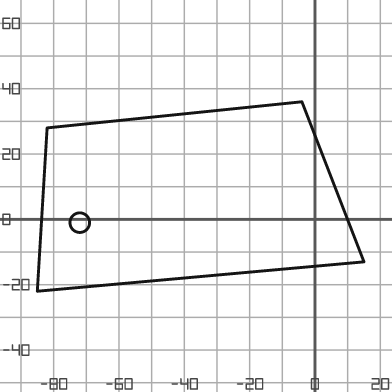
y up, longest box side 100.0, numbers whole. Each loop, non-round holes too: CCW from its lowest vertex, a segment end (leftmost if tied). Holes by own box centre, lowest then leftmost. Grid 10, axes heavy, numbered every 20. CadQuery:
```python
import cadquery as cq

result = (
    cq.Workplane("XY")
    .moveTo(-85.0, -22.0)
    .lineTo(15.0, -13.0)
    .lineTo(-4.0, 36.0)
    .lineTo(-82.0, 28.0)
    .close()
    .moveTo(-72.0, -1.0)
    .circle(3.0)
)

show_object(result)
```